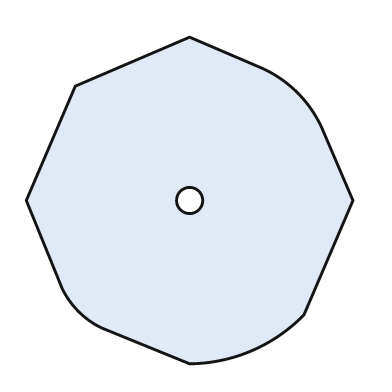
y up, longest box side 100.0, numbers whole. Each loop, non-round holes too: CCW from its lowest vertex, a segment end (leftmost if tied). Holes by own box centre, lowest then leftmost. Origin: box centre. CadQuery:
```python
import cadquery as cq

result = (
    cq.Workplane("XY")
    .moveTo(0.0, -50.0)
    .threePointArc((19.0, -46.0), (35.0, -35.0))
    .lineTo(50.0, 0.0)
    .lineTo(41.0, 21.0)
    .threePointArc((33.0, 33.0), (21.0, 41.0))
    .lineTo(0.0, 50.0)
    .lineTo(-35.0, 35.0)
    .lineTo(-50.0, 0.0)
    .lineTo(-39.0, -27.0)
    .threePointArc((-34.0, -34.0), (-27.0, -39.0))
    .close()
    .moveTo(0.0, 0.0)
    .circle(4.0)
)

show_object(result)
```